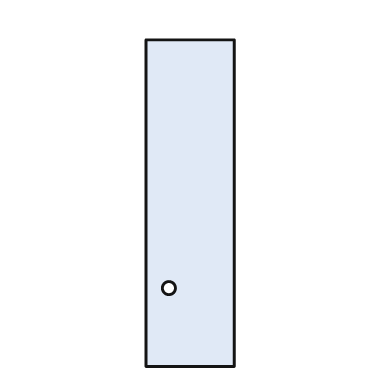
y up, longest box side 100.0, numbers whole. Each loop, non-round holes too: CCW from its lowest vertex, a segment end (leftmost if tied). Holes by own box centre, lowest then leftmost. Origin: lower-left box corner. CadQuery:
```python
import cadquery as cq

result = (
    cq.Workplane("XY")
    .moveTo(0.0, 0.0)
    .lineTo(27.0, 0.0)
    .lineTo(27.0, 100.0)
    .lineTo(0.0, 100.0)
    .close()
    .moveTo(7.0, 24.0)
    .circle(2.0)
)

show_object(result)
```